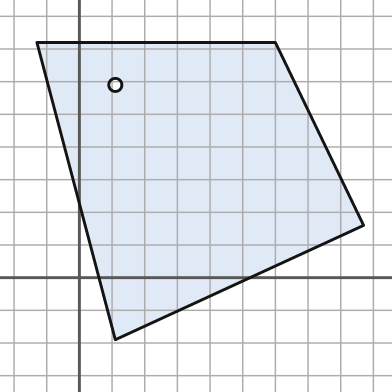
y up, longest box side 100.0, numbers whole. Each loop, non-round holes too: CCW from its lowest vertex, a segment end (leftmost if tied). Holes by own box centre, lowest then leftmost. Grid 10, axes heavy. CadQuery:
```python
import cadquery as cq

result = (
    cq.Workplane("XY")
    .moveTo(11.0, -19.0)
    .lineTo(87.0, 16.0)
    .lineTo(60.0, 72.0)
    .lineTo(-13.0, 72.0)
    .close()
    .moveTo(11.0, 59.0)
    .circle(2.0)
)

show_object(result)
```